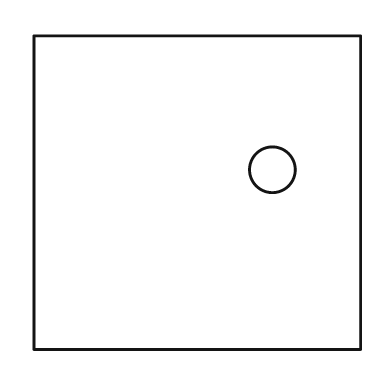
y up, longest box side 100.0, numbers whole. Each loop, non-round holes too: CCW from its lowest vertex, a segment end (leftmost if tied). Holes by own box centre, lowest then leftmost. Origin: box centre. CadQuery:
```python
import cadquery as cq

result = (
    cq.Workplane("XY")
    .moveTo(-50.0, -48.0)
    .lineTo(50.0, -48.0)
    .lineTo(50.0, 48.0)
    .lineTo(-50.0, 48.0)
    .close()
    .moveTo(23.0, 7.0)
    .circle(7.0)
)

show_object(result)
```